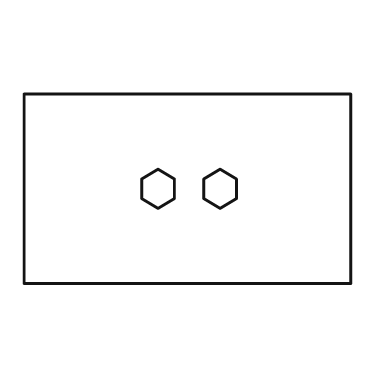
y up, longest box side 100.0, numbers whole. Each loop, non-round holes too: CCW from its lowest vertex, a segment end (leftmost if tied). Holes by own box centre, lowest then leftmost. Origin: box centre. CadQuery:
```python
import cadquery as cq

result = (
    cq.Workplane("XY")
    .moveTo(-50.0, -29.0)
    .lineTo(50.0, -29.0)
    .lineTo(50.0, 29.0)
    .lineTo(-50.0, 29.0)
    .close()
    .moveTo(-9.0, -6.0)
    .lineTo(-4.0, -3.0)
    .lineTo(-4.0, 3.0)
    .lineTo(-9.0, 6.0)
    .lineTo(-14.0, 3.0)
    .lineTo(-14.0, -3.0)
    .close()
    .moveTo(10.0, -6.0)
    .lineTo(15.0, -3.0)
    .lineTo(15.0, 3.0)
    .lineTo(10.0, 6.0)
    .lineTo(5.0, 3.0)
    .lineTo(5.0, -3.0)
    .close()
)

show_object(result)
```